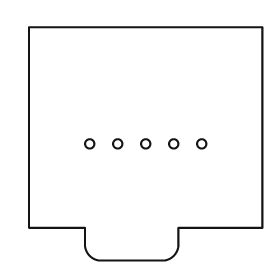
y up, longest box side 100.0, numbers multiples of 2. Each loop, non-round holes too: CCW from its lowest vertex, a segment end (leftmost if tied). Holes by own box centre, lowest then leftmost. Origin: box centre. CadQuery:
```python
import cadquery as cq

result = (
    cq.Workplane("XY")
    .moveTo(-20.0, -50.0)
    .lineTo(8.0, -50.0)
    .threePointArc((12.0, -48.0), (14.0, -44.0))
    .lineTo(14.0, -36.0)
    .lineTo(50.0, -36.0)
    .lineTo(50.0, 50.0)
    .lineTo(-50.0, 50.0)
    .lineTo(-50.0, -36.0)
    .lineTo(-26.0, -36.0)
    .lineTo(-26.0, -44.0)
    .threePointArc((-24.0, -48.0), (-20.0, -50.0))
    .close()
    .moveTo(-24.0, 0.0)
    .circle(2.0)
    .moveTo(-12.0, 0.0)
    .circle(2.0)
    .moveTo(0.0, 0.0)
    .circle(2.0)
    .moveTo(12.0, 0.0)
    .circle(2.0)
    .moveTo(24.0, 0.0)
    .circle(2.0)
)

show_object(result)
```